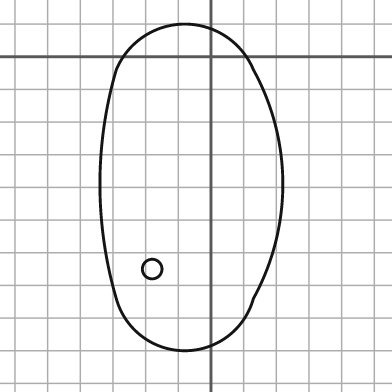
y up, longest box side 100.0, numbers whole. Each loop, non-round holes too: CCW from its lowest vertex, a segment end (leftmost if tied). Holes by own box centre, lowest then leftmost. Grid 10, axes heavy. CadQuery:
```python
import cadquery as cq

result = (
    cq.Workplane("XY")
    .moveTo(-29.0, -74.0)
    .threePointArc((-8.0, -90.0), (13.0, -74.0))
    .threePointArc((22.0, -39.0), (13.0, -4.0))
    .threePointArc((-8.0, 10.0), (-29.0, -4.0))
    .threePointArc((-34.0, -39.0), (-29.0, -74.0))
    .close()
    .moveTo(-18.0, -65.0)
    .circle(3.0)
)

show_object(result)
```